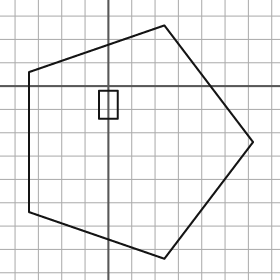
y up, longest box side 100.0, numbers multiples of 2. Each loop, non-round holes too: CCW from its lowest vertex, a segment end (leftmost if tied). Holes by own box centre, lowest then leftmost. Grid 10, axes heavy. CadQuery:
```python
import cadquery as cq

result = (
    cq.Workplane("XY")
    .moveTo(24.0, -74.0)
    .lineTo(62.0, -24.0)
    .lineTo(24.0, 26.0)
    .lineTo(-34.0, 6.0)
    .lineTo(-34.0, -54.0)
    .close()
    .moveTo(-4.0, -14.0)
    .lineTo(4.0, -14.0)
    .lineTo(4.0, -2.0)
    .lineTo(-4.0, -2.0)
    .close()
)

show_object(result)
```